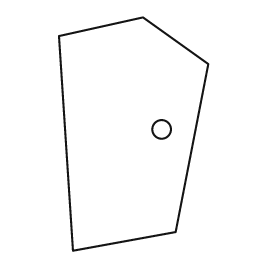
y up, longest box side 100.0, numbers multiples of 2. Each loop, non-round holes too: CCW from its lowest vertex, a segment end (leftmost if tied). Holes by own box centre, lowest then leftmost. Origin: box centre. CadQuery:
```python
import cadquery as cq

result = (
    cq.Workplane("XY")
    .moveTo(-26.0, -50.0)
    .lineTo(18.0, -42.0)
    .lineTo(32.0, 30.0)
    .lineTo(4.0, 50.0)
    .lineTo(-32.0, 42.0)
    .close()
    .moveTo(12.0, 2.0)
    .circle(4.0)
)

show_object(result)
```